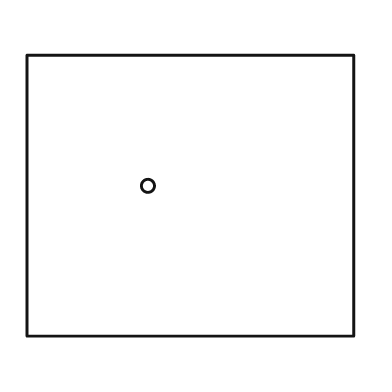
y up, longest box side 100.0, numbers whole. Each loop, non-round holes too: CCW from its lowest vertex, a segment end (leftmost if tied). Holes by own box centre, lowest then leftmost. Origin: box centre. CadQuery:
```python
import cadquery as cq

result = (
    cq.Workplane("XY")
    .moveTo(-50.0, -43.0)
    .lineTo(50.0, -43.0)
    .lineTo(50.0, 43.0)
    .lineTo(-50.0, 43.0)
    .close()
    .moveTo(-13.0, 3.0)
    .circle(2.0)
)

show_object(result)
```